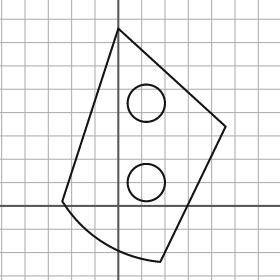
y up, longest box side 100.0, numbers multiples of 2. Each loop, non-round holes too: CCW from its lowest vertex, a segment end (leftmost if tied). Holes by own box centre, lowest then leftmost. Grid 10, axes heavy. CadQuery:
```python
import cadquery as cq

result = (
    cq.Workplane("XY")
    .moveTo(18.0, -24.0)
    .lineTo(46.0, 34.0)
    .lineTo(0.0, 76.0)
    .lineTo(-24.0, 2.0)
    .threePointArc((-6.0, -16.0), (18.0, -24.0))
    .close()
    .moveTo(12.0, 10.0)
    .circle(8.0)
    .moveTo(12.0, 44.0)
    .circle(8.0)
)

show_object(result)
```